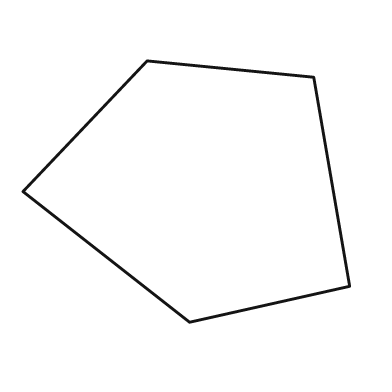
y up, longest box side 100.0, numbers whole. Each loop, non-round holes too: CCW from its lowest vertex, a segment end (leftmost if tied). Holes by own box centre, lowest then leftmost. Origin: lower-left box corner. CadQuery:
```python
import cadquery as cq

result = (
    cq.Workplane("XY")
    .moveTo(51.0, 0.0)
    .lineTo(100.0, 11.0)
    .lineTo(89.0, 75.0)
    .lineTo(38.0, 80.0)
    .lineTo(0.0, 40.0)
    .close()
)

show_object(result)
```